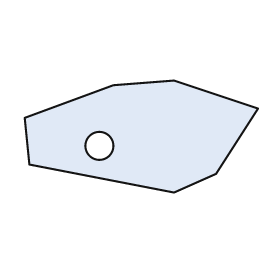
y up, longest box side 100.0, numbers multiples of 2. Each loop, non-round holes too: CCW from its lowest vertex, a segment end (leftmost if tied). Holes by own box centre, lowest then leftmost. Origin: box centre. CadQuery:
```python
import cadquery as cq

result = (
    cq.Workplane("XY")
    .moveTo(14.0, -24.0)
    .lineTo(32.0, -16.0)
    .lineTo(50.0, 12.0)
    .lineTo(14.0, 24.0)
    .lineTo(-12.0, 22.0)
    .lineTo(-50.0, 8.0)
    .lineTo(-48.0, -12.0)
    .close()
    .moveTo(-18.0, -4.0)
    .circle(6.0)
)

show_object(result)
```